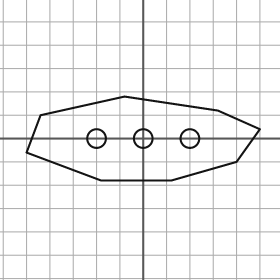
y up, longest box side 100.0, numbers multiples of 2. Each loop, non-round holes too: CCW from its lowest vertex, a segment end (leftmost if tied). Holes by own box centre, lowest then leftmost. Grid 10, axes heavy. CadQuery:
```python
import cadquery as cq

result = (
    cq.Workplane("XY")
    .moveTo(-18.0, -18.0)
    .lineTo(12.0, -18.0)
    .lineTo(40.0, -10.0)
    .lineTo(50.0, 4.0)
    .lineTo(32.0, 12.0)
    .lineTo(-8.0, 18.0)
    .lineTo(-44.0, 10.0)
    .lineTo(-50.0, -6.0)
    .close()
    .moveTo(-20.0, 0.0)
    .circle(4.0)
    .moveTo(0.0, 0.0)
    .circle(4.0)
    .moveTo(20.0, 0.0)
    .circle(4.0)
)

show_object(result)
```